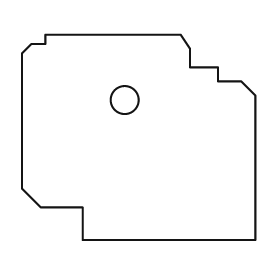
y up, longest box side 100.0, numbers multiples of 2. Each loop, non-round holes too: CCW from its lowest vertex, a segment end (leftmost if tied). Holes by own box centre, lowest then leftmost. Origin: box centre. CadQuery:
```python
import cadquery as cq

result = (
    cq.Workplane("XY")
    .moveTo(-24.0, -44.0)
    .lineTo(50.0, -44.0)
    .lineTo(50.0, 18.0)
    .lineTo(44.0, 24.0)
    .lineTo(34.0, 24.0)
    .lineTo(34.0, 30.0)
    .lineTo(22.0, 30.0)
    .lineTo(22.0, 38.0)
    .lineTo(18.0, 44.0)
    .lineTo(-40.0, 44.0)
    .lineTo(-40.0, 40.0)
    .lineTo(-46.0, 40.0)
    .lineTo(-50.0, 36.0)
    .lineTo(-50.0, -22.0)
    .lineTo(-42.0, -30.0)
    .lineTo(-24.0, -30.0)
    .close()
    .moveTo(-6.0, 16.0)
    .circle(6.0)
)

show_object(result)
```